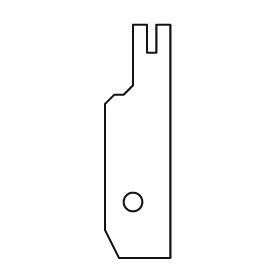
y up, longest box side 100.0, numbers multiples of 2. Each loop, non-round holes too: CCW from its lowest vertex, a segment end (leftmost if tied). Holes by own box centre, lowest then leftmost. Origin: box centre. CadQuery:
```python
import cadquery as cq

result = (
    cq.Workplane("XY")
    .moveTo(-8.0, -50.0)
    .lineTo(14.0, -50.0)
    .lineTo(14.0, 50.0)
    .lineTo(8.0, 50.0)
    .lineTo(8.0, 38.0)
    .lineTo(4.0, 38.0)
    .lineTo(4.0, 50.0)
    .lineTo(-2.0, 50.0)
    .lineTo(-2.0, 24.0)
    .lineTo(-6.0, 20.0)
    .lineTo(-10.0, 20.0)
    .lineTo(-14.0, 16.0)
    .lineTo(-14.0, -38.0)
    .close()
    .moveTo(-2.0, -26.0)
    .circle(4.0)
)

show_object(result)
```